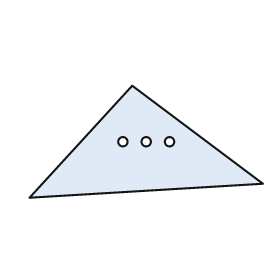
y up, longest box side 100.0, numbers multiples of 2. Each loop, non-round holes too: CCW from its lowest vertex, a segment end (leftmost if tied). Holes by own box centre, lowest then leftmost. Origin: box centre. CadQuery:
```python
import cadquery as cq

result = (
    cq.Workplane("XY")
    .moveTo(-50.0, -24.0)
    .lineTo(50.0, -18.0)
    .lineTo(-6.0, 24.0)
    .close()
    .moveTo(-10.0, 0.0)
    .circle(2.0)
    .moveTo(0.0, 0.0)
    .circle(2.0)
    .moveTo(10.0, 0.0)
    .circle(2.0)
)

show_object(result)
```